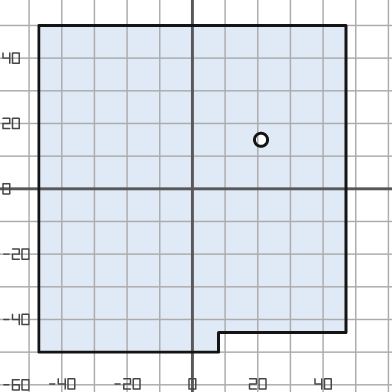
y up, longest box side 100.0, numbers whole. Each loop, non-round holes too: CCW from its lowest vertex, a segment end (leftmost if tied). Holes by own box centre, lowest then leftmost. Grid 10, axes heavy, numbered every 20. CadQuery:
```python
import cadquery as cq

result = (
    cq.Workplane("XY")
    .moveTo(-47.0, -50.0)
    .lineTo(8.0, -50.0)
    .lineTo(8.0, -44.0)
    .lineTo(47.0, -44.0)
    .lineTo(47.0, 50.0)
    .lineTo(-47.0, 50.0)
    .close()
    .moveTo(21.0, 15.0)
    .circle(2.0)
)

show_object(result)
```